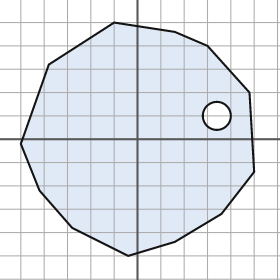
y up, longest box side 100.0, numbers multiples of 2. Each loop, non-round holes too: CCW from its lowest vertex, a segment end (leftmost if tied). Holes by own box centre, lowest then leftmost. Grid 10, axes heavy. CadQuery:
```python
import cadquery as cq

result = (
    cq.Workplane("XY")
    .moveTo(-4.0, -50.0)
    .lineTo(16.0, -44.0)
    .lineTo(36.0, -32.0)
    .lineTo(50.0, -14.0)
    .lineTo(48.0, 20.0)
    .lineTo(30.0, 40.0)
    .lineTo(16.0, 46.0)
    .lineTo(-10.0, 50.0)
    .lineTo(-38.0, 32.0)
    .lineTo(-50.0, -2.0)
    .lineTo(-42.0, -22.0)
    .lineTo(-28.0, -38.0)
    .close()
    .moveTo(34.0, 10.0)
    .circle(6.0)
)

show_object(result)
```